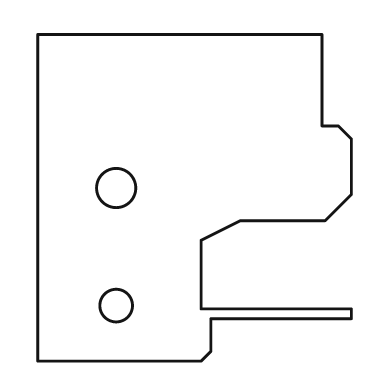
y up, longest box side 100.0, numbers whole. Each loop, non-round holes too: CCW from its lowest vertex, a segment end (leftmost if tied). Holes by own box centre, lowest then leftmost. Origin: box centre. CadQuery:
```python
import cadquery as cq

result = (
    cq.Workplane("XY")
    .moveTo(-48.0, -50.0)
    .lineTo(2.0, -50.0)
    .lineTo(5.0, -47.0)
    .lineTo(5.0, -37.0)
    .lineTo(48.0, -37.0)
    .lineTo(48.0, -34.0)
    .lineTo(2.0, -34.0)
    .lineTo(2.0, -13.0)
    .lineTo(14.0, -7.0)
    .lineTo(40.0, -7.0)
    .lineTo(48.0, 1.0)
    .lineTo(48.0, 18.0)
    .lineTo(44.0, 22.0)
    .lineTo(39.0, 22.0)
    .lineTo(39.0, 50.0)
    .lineTo(-48.0, 50.0)
    .close()
    .moveTo(-24.0, -33.0)
    .circle(5.0)
    .moveTo(-24.0, 3.0)
    .circle(6.0)
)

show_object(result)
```